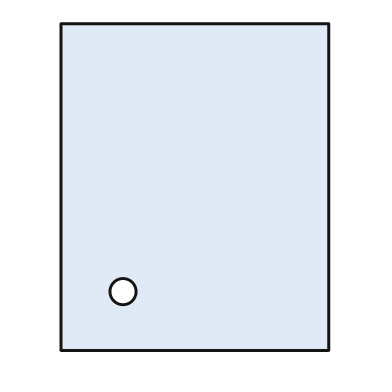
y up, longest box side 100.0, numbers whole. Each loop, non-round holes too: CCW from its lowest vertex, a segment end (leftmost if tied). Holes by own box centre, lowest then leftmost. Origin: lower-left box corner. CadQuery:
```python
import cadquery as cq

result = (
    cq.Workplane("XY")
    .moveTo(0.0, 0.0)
    .lineTo(82.0, 0.0)
    .lineTo(82.0, 100.0)
    .lineTo(0.0, 100.0)
    .close()
    .moveTo(19.0, 18.0)
    .circle(4.0)
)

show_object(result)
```